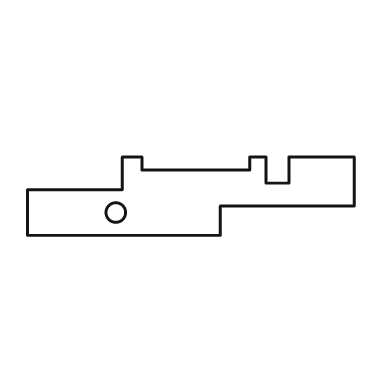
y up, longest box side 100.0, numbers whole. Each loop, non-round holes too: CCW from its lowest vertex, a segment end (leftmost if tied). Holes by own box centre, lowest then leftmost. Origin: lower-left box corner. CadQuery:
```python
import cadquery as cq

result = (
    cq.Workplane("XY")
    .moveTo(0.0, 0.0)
    .lineTo(59.0, 0.0)
    .lineTo(59.0, 9.0)
    .lineTo(100.0, 9.0)
    .lineTo(100.0, 24.0)
    .lineTo(80.0, 24.0)
    .lineTo(80.0, 16.0)
    .lineTo(73.0, 16.0)
    .lineTo(73.0, 24.0)
    .lineTo(68.0, 24.0)
    .lineTo(68.0, 20.0)
    .lineTo(35.0, 20.0)
    .lineTo(35.0, 24.0)
    .lineTo(29.0, 24.0)
    .lineTo(29.0, 14.0)
    .lineTo(0.0, 14.0)
    .close()
    .moveTo(27.0, 7.0)
    .circle(3.0)
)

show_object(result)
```